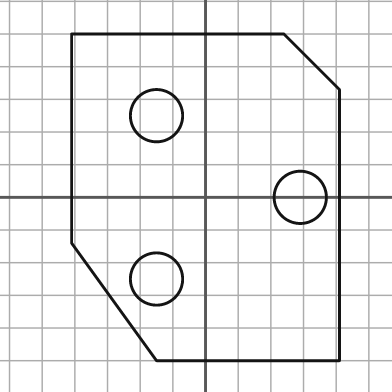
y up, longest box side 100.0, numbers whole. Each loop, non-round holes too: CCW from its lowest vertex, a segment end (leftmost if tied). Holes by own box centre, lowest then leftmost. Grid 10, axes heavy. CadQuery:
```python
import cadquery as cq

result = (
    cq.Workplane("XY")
    .moveTo(-15.0, -50.0)
    .lineTo(41.0, -50.0)
    .lineTo(41.0, 33.0)
    .lineTo(24.0, 50.0)
    .lineTo(-41.0, 50.0)
    .lineTo(-41.0, -14.0)
    .close()
    .moveTo(-15.0, -25.0)
    .circle(8.0)
    .moveTo(29.0, 0.0)
    .circle(8.0)
    .moveTo(-15.0, 25.0)
    .circle(8.0)
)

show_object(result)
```